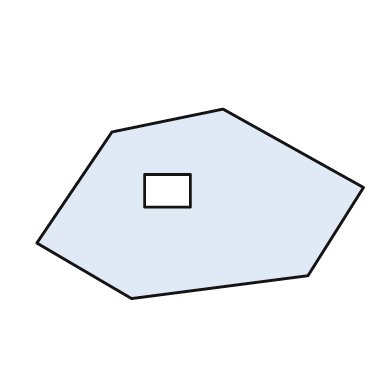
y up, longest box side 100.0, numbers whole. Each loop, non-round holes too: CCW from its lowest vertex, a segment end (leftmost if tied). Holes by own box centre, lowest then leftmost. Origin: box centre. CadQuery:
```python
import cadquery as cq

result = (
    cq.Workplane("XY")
    .moveTo(-21.0, -29.0)
    .lineTo(33.0, -22.0)
    .lineTo(50.0, 5.0)
    .lineTo(7.0, 29.0)
    .lineTo(-27.0, 22.0)
    .lineTo(-50.0, -12.0)
    .close()
    .moveTo(-17.0, -1.0)
    .lineTo(-3.0, -1.0)
    .lineTo(-3.0, 9.0)
    .lineTo(-17.0, 9.0)
    .close()
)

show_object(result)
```